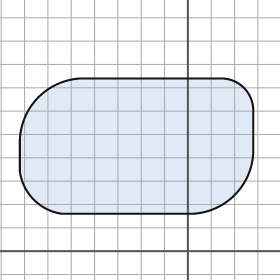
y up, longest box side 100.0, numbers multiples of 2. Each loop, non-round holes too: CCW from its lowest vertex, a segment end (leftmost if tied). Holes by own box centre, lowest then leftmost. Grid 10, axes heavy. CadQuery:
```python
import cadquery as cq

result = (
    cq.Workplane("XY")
    .moveTo(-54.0, 16.0)
    .lineTo(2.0, 16.0)
    .threePointArc((20.0, 24.0), (28.0, 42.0))
    .lineTo(28.0, 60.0)
    .threePointArc((24.0, 70.0), (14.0, 74.0))
    .lineTo(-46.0, 74.0)
    .threePointArc((-64.0, 66.0), (-72.0, 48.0))
    .lineTo(-72.0, 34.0)
    .threePointArc((-66.0, 22.0), (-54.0, 16.0))
    .close()
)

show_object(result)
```